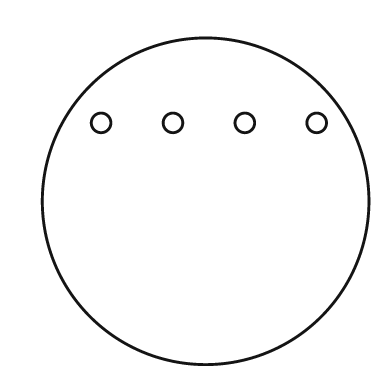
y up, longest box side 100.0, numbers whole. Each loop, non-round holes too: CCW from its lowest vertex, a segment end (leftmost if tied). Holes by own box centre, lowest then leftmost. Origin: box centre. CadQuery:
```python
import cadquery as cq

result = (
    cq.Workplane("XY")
    .moveTo(0.0, 0.0)
    .circle(50.0)
    .moveTo(-32.0, 24.0)
    .circle(3.0)
    .moveTo(-10.0, 24.0)
    .circle(3.0)
    .moveTo(12.0, 24.0)
    .circle(3.0)
    .moveTo(34.0, 24.0)
    .circle(3.0)
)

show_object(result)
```